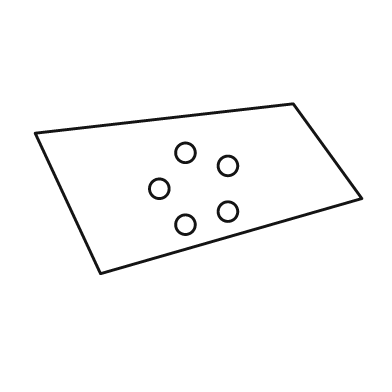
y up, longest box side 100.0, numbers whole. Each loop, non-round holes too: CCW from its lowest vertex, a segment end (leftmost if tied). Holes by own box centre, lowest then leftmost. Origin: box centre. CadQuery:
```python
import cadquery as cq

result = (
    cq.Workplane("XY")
    .moveTo(-30.0, -26.0)
    .lineTo(50.0, -3.0)
    .lineTo(29.0, 26.0)
    .lineTo(-50.0, 17.0)
    .close()
    .moveTo(-4.0, -11.0)
    .circle(3.0)
    .moveTo(9.0, -7.0)
    .circle(3.0)
    .moveTo(-12.0, 0.0)
    .circle(3.0)
    .moveTo(9.0, 7.0)
    .circle(3.0)
    .moveTo(-4.0, 11.0)
    .circle(3.0)
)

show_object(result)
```